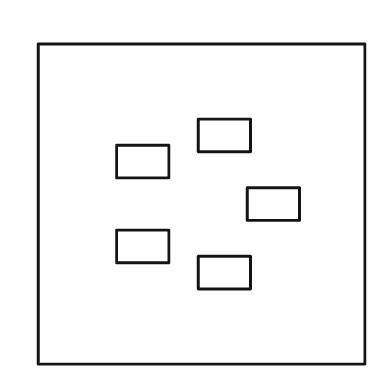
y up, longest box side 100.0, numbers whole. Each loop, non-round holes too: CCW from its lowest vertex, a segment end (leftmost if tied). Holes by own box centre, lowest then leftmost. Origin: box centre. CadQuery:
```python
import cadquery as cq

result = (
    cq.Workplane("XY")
    .moveTo(-50.0, -49.0)
    .lineTo(50.0, -49.0)
    .lineTo(50.0, 49.0)
    .lineTo(-50.0, 49.0)
    .close()
    .moveTo(-1.0, -26.0)
    .lineTo(15.0, -26.0)
    .lineTo(15.0, -16.0)
    .lineTo(-1.0, -16.0)
    .close()
    .moveTo(-26.0, -18.0)
    .lineTo(-10.0, -18.0)
    .lineTo(-10.0, -8.0)
    .lineTo(-26.0, -8.0)
    .close()
    .moveTo(14.0, -5.0)
    .lineTo(30.0, -5.0)
    .lineTo(30.0, 5.0)
    .lineTo(14.0, 5.0)
    .close()
    .moveTo(-26.0, 8.0)
    .lineTo(-10.0, 8.0)
    .lineTo(-10.0, 18.0)
    .lineTo(-26.0, 18.0)
    .close()
    .moveTo(-1.0, 16.0)
    .lineTo(15.0, 16.0)
    .lineTo(15.0, 26.0)
    .lineTo(-1.0, 26.0)
    .close()
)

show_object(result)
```